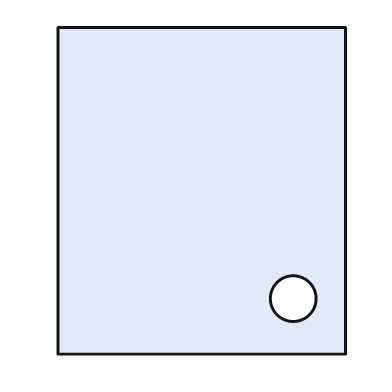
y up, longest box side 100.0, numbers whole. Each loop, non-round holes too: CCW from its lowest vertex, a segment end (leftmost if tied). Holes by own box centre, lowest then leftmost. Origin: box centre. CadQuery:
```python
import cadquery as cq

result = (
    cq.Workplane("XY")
    .moveTo(-44.0, -50.0)
    .lineTo(44.0, -50.0)
    .lineTo(44.0, 50.0)
    .lineTo(-44.0, 50.0)
    .close()
    .moveTo(28.0, -33.0)
    .circle(7.0)
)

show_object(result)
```